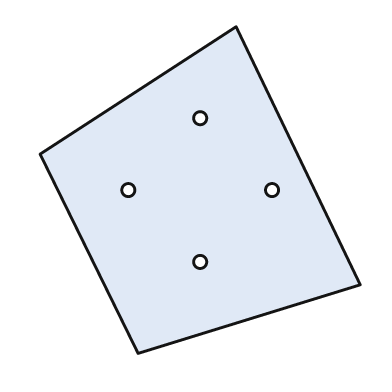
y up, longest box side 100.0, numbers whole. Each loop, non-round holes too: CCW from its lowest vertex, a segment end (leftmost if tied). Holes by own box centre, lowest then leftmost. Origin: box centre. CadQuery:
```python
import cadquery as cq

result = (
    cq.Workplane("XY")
    .moveTo(-19.0, -50.0)
    .lineTo(49.0, -29.0)
    .lineTo(11.0, 50.0)
    .lineTo(-49.0, 11.0)
    .close()
    .moveTo(0.0, -22.0)
    .circle(2.0)
    .moveTo(-22.0, 0.0)
    .circle(2.0)
    .moveTo(22.0, 0.0)
    .circle(2.0)
    .moveTo(0.0, 22.0)
    .circle(2.0)
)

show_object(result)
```